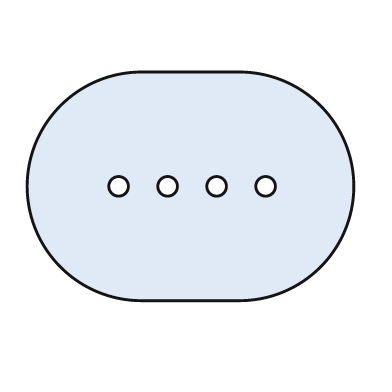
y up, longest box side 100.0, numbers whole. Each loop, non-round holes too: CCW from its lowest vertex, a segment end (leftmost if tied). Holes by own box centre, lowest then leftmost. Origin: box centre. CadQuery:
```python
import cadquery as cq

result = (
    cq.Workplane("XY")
    .moveTo(-15.0, -35.0)
    .lineTo(15.0, -35.0)
    .threePointArc((50.0, 0.0), (15.0, 35.0))
    .lineTo(-15.0, 35.0)
    .threePointArc((-50.0, 0.0), (-15.0, -35.0))
    .close()
    .moveTo(-22.0, 0.0)
    .circle(3.0)
    .moveTo(-7.0, 0.0)
    .circle(3.0)
    .moveTo(8.0, 0.0)
    .circle(3.0)
    .moveTo(23.0, 0.0)
    .circle(3.0)
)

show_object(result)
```